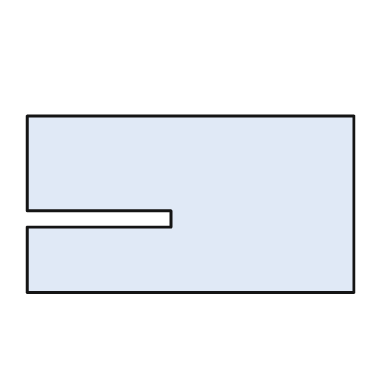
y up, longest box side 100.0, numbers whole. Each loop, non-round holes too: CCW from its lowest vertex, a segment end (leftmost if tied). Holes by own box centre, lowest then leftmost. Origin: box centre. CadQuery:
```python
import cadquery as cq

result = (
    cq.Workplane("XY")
    .moveTo(-50.0, -27.0)
    .lineTo(50.0, -27.0)
    .lineTo(50.0, 27.0)
    .lineTo(-50.0, 27.0)
    .lineTo(-50.0, -2.0)
    .lineTo(-6.0, -2.0)
    .lineTo(-6.0, -7.0)
    .lineTo(-50.0, -7.0)
    .close()
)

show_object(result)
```